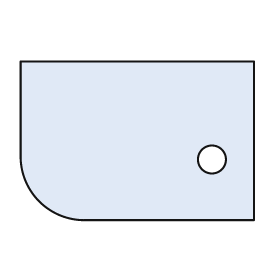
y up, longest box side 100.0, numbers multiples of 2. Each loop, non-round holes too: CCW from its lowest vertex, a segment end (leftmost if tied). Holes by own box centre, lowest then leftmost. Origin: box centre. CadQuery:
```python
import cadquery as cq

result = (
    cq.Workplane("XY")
    .moveTo(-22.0, -34.0)
    .lineTo(50.0, -34.0)
    .lineTo(50.0, 34.0)
    .lineTo(-50.0, 34.0)
    .lineTo(-50.0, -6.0)
    .threePointArc((-42.0, -26.0), (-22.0, -34.0))
    .close()
    .moveTo(32.0, -8.0)
    .circle(6.0)
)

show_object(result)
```